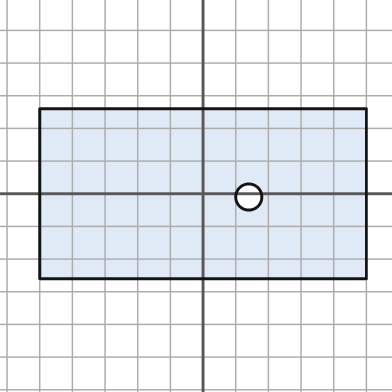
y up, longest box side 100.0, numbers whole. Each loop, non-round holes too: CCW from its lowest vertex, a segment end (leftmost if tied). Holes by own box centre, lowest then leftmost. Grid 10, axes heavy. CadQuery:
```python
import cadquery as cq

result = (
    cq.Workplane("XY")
    .moveTo(-50.0, -26.0)
    .lineTo(50.0, -26.0)
    .lineTo(50.0, 26.0)
    .lineTo(-50.0, 26.0)
    .close()
    .moveTo(14.0, -1.0)
    .circle(4.0)
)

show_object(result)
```